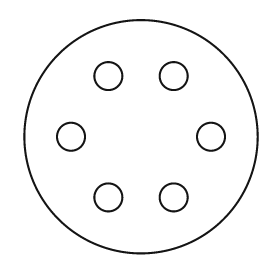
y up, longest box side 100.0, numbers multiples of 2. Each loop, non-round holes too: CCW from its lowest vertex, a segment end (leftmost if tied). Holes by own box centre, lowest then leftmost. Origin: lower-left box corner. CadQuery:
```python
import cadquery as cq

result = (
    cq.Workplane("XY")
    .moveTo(50.0, 50.0)
    .circle(50.0)
    .moveTo(36.0, 24.0)
    .circle(6.0)
    .moveTo(64.0, 24.0)
    .circle(6.0)
    .moveTo(20.0, 50.0)
    .circle(6.0)
    .moveTo(80.0, 50.0)
    .circle(6.0)
    .moveTo(36.0, 76.0)
    .circle(6.0)
    .moveTo(64.0, 76.0)
    .circle(6.0)
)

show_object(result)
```